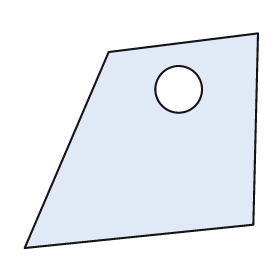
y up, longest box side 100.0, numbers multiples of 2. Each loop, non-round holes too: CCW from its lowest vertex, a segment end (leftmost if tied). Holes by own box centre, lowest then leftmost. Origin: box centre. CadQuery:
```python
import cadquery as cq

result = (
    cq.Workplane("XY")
    .moveTo(-50.0, -46.0)
    .lineTo(48.0, -36.0)
    .lineTo(50.0, 46.0)
    .lineTo(-14.0, 38.0)
    .close()
    .moveTo(16.0, 22.0)
    .circle(10.0)
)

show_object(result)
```